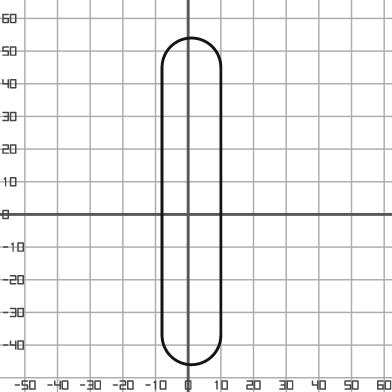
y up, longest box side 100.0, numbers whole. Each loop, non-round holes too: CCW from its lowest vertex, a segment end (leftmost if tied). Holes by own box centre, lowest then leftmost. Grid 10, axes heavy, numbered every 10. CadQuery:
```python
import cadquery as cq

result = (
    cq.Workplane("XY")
    .moveTo(-8.0, -37.0)
    .threePointArc((1.0, -46.0), (10.0, -37.0))
    .lineTo(10.0, 45.0)
    .threePointArc((1.0, 54.0), (-8.0, 45.0))
    .close()
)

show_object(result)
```